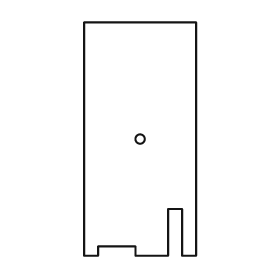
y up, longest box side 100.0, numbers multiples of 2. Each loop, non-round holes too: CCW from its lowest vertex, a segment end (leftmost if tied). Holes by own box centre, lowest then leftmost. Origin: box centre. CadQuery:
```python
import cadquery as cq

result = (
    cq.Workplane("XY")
    .moveTo(-24.0, -50.0)
    .lineTo(-18.0, -50.0)
    .lineTo(-18.0, -46.0)
    .lineTo(-2.0, -46.0)
    .lineTo(-2.0, -50.0)
    .lineTo(12.0, -50.0)
    .lineTo(12.0, -30.0)
    .lineTo(18.0, -30.0)
    .lineTo(18.0, -50.0)
    .lineTo(24.0, -50.0)
    .lineTo(24.0, 50.0)
    .lineTo(-24.0, 50.0)
    .close()
    .moveTo(0.0, 0.0)
    .circle(2.0)
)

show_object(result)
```